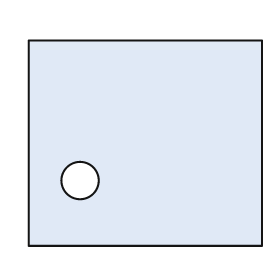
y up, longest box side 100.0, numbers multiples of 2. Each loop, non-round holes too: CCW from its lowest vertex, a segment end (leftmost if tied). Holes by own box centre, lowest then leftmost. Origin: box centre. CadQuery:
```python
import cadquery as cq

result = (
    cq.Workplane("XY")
    .moveTo(-50.0, -44.0)
    .lineTo(50.0, -44.0)
    .lineTo(50.0, 44.0)
    .lineTo(-50.0, 44.0)
    .close()
    .moveTo(-28.0, -16.0)
    .circle(8.0)
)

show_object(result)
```